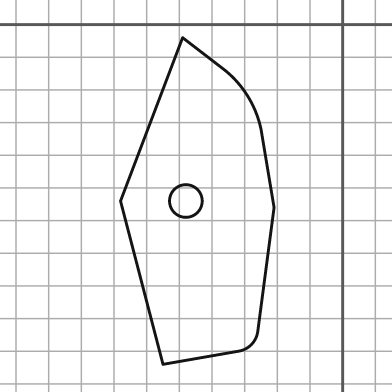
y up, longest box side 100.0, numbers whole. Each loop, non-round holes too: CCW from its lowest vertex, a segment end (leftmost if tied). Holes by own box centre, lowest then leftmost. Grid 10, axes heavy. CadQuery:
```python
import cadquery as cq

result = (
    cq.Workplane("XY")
    .moveTo(-55.0, -104.0)
    .lineTo(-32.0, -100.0)
    .threePointArc((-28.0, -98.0), (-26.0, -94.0))
    .lineTo(-21.0, -56.0)
    .lineTo(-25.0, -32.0)
    .threePointArc((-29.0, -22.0), (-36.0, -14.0))
    .lineTo(-49.0, -4.0)
    .lineTo(-68.0, -54.0)
    .close()
    .moveTo(-48.0, -54.0)
    .circle(5.0)
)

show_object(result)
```